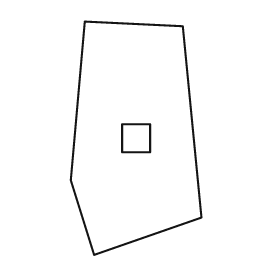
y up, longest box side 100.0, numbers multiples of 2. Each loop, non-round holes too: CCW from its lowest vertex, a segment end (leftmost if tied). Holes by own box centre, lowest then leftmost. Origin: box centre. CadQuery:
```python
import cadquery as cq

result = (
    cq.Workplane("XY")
    .moveTo(-18.0, -50.0)
    .lineTo(28.0, -34.0)
    .lineTo(20.0, 48.0)
    .lineTo(-22.0, 50.0)
    .lineTo(-28.0, -18.0)
    .close()
    .moveTo(-6.0, -6.0)
    .lineTo(6.0, -6.0)
    .lineTo(6.0, 6.0)
    .lineTo(-6.0, 6.0)
    .close()
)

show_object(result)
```